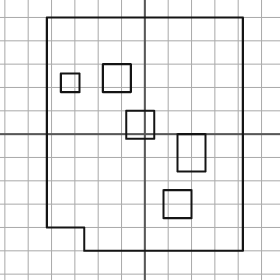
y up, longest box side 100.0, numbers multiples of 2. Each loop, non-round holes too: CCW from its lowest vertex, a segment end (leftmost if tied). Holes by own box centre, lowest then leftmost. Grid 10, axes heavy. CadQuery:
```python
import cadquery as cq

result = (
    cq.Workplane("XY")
    .moveTo(-26.0, -50.0)
    .lineTo(42.0, -50.0)
    .lineTo(42.0, 50.0)
    .lineTo(-42.0, 50.0)
    .lineTo(-42.0, -40.0)
    .lineTo(-26.0, -40.0)
    .close()
    .moveTo(8.0, -36.0)
    .lineTo(20.0, -36.0)
    .lineTo(20.0, -24.0)
    .lineTo(8.0, -24.0)
    .close()
    .moveTo(14.0, -16.0)
    .lineTo(26.0, -16.0)
    .lineTo(26.0, 0.0)
    .lineTo(14.0, 0.0)
    .close()
    .moveTo(-8.0, -2.0)
    .lineTo(4.0, -2.0)
    .lineTo(4.0, 10.0)
    .lineTo(-8.0, 10.0)
    .close()
    .moveTo(-36.0, 18.0)
    .lineTo(-28.0, 18.0)
    .lineTo(-28.0, 26.0)
    .lineTo(-36.0, 26.0)
    .close()
    .moveTo(-18.0, 18.0)
    .lineTo(-6.0, 18.0)
    .lineTo(-6.0, 30.0)
    .lineTo(-18.0, 30.0)
    .close()
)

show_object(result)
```